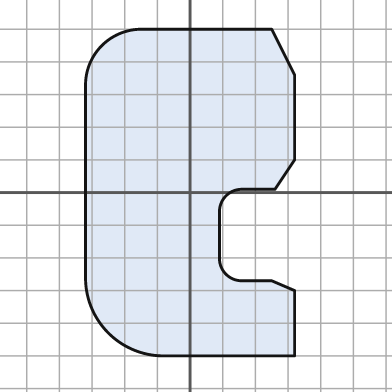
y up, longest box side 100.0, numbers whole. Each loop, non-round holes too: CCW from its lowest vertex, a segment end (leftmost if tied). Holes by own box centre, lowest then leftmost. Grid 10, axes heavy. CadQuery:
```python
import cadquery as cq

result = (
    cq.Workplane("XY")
    .moveTo(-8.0, -50.0)
    .lineTo(32.0, -50.0)
    .lineTo(32.0, -30.0)
    .lineTo(25.0, -27.0)
    .lineTo(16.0, -27.0)
    .threePointArc((11.0, -25.0), (9.0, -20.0))
    .lineTo(9.0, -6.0)
    .threePointArc((11.0, -1.0), (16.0, 1.0))
    .lineTo(26.0, 1.0)
    .lineTo(32.0, 10.0)
    .lineTo(32.0, 36.0)
    .lineTo(25.0, 50.0)
    .lineTo(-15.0, 50.0)
    .threePointArc((-27.0, 45.0), (-32.0, 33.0))
    .lineTo(-32.0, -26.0)
    .threePointArc((-25.0, -43.0), (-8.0, -50.0))
    .close()
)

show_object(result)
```